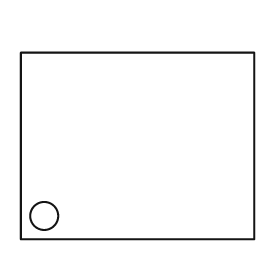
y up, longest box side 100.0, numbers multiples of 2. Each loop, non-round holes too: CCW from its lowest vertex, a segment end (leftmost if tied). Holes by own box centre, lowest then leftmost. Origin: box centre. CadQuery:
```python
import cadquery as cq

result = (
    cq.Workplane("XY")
    .moveTo(-50.0, -40.0)
    .lineTo(50.0, -40.0)
    .lineTo(50.0, 40.0)
    .lineTo(-50.0, 40.0)
    .close()
    .moveTo(-40.0, -30.0)
    .circle(6.0)
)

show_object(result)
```